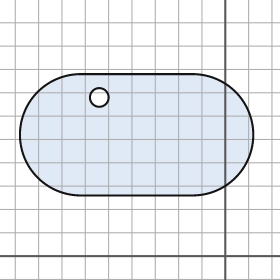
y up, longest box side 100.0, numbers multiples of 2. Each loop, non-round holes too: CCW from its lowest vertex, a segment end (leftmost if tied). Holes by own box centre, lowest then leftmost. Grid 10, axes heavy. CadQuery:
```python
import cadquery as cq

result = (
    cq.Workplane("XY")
    .moveTo(-62.0, 26.0)
    .lineTo(-14.0, 26.0)
    .threePointArc((12.0, 52.0), (-14.0, 78.0))
    .lineTo(-62.0, 78.0)
    .threePointArc((-88.0, 52.0), (-62.0, 26.0))
    .close()
    .moveTo(-54.0, 68.0)
    .circle(4.0)
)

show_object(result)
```